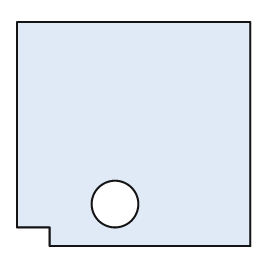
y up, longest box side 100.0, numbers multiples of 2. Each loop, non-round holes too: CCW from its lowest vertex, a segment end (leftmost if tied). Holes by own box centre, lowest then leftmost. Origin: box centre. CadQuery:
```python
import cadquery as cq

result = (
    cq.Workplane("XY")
    .moveTo(-36.0, -48.0)
    .lineTo(50.0, -48.0)
    .lineTo(50.0, 48.0)
    .lineTo(-50.0, 48.0)
    .lineTo(-50.0, -40.0)
    .lineTo(-36.0, -40.0)
    .close()
    .moveTo(-8.0, -30.0)
    .circle(10.0)
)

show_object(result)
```